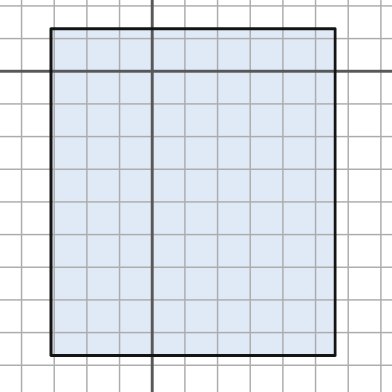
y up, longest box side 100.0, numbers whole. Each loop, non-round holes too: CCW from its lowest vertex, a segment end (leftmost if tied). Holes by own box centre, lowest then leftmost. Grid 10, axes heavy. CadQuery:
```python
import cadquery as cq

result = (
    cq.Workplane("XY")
    .moveTo(-31.0, -87.0)
    .lineTo(56.0, -87.0)
    .lineTo(56.0, 13.0)
    .lineTo(-31.0, 13.0)
    .close()
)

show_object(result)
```